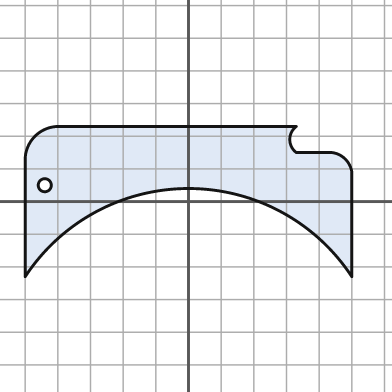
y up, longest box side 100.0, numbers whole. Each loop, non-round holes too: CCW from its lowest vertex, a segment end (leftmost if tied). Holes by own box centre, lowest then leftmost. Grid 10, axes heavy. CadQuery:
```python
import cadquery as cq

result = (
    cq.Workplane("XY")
    .moveTo(-50.0, -23.0)
    .threePointArc((0.0, 4.0), (50.0, -23.0))
    .lineTo(50.0, 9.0)
    .threePointArc((48.0, 13.0), (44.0, 15.0))
    .lineTo(33.0, 15.0)
    .threePointArc((31.0, 19.0), (33.0, 23.0))
    .lineTo(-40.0, 23.0)
    .threePointArc((-47.0, 20.0), (-50.0, 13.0))
    .close()
    .moveTo(-44.0, 5.0)
    .circle(2.0)
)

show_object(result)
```